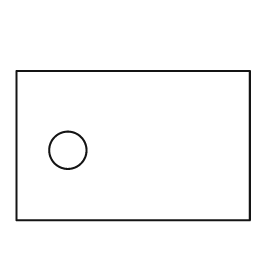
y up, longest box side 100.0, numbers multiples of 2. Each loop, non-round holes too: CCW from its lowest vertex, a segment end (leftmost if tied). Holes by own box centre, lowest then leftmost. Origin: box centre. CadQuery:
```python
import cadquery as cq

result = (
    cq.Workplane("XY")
    .moveTo(-50.0, -32.0)
    .lineTo(50.0, -32.0)
    .lineTo(50.0, 32.0)
    .lineTo(-50.0, 32.0)
    .close()
    .moveTo(-28.0, -2.0)
    .circle(8.0)
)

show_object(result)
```